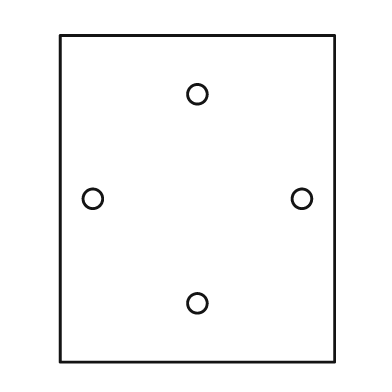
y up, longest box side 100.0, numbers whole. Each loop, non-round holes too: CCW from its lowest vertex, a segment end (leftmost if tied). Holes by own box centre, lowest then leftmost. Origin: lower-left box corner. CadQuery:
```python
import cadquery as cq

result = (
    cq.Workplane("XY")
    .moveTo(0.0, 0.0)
    .lineTo(84.0, 0.0)
    .lineTo(84.0, 100.0)
    .lineTo(0.0, 100.0)
    .close()
    .moveTo(42.0, 18.0)
    .circle(3.0)
    .moveTo(10.0, 50.0)
    .circle(3.0)
    .moveTo(74.0, 50.0)
    .circle(3.0)
    .moveTo(42.0, 82.0)
    .circle(3.0)
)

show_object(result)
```